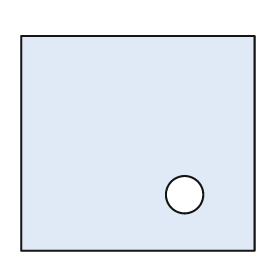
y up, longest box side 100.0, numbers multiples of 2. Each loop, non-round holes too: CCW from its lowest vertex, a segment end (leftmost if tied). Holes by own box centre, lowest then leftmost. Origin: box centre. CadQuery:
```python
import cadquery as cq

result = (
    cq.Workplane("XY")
    .moveTo(-50.0, -46.0)
    .lineTo(50.0, -46.0)
    .lineTo(50.0, 46.0)
    .lineTo(-50.0, 46.0)
    .close()
    .moveTo(20.0, -22.0)
    .circle(8.0)
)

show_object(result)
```